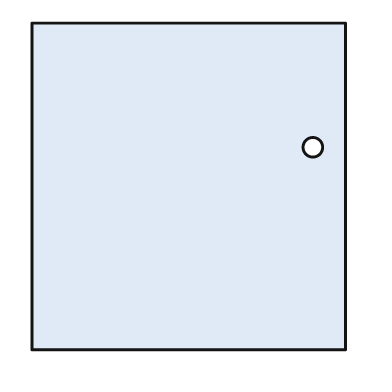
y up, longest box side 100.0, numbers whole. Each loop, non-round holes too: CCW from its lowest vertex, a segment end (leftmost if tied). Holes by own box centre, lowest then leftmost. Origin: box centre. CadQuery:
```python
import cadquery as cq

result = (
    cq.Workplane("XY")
    .moveTo(-48.0, -50.0)
    .lineTo(48.0, -50.0)
    .lineTo(48.0, 50.0)
    .lineTo(-48.0, 50.0)
    .close()
    .moveTo(38.0, 12.0)
    .circle(3.0)
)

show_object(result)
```